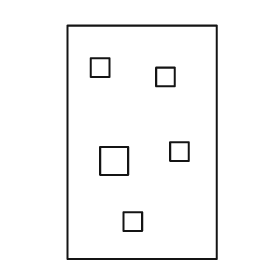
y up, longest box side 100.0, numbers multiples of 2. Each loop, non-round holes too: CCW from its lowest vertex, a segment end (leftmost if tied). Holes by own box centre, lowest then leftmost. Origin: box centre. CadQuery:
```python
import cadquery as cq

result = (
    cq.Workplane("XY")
    .moveTo(-32.0, -50.0)
    .lineTo(32.0, -50.0)
    .lineTo(32.0, 50.0)
    .lineTo(-32.0, 50.0)
    .close()
    .moveTo(-8.0, -38.0)
    .lineTo(0.0, -38.0)
    .lineTo(0.0, -30.0)
    .lineTo(-8.0, -30.0)
    .close()
    .moveTo(-18.0, -14.0)
    .lineTo(-6.0, -14.0)
    .lineTo(-6.0, -2.0)
    .lineTo(-18.0, -2.0)
    .close()
    .moveTo(12.0, -8.0)
    .lineTo(20.0, -8.0)
    .lineTo(20.0, 0.0)
    .lineTo(12.0, 0.0)
    .close()
    .moveTo(6.0, 24.0)
    .lineTo(14.0, 24.0)
    .lineTo(14.0, 32.0)
    .lineTo(6.0, 32.0)
    .close()
    .moveTo(-22.0, 28.0)
    .lineTo(-14.0, 28.0)
    .lineTo(-14.0, 36.0)
    .lineTo(-22.0, 36.0)
    .close()
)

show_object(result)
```